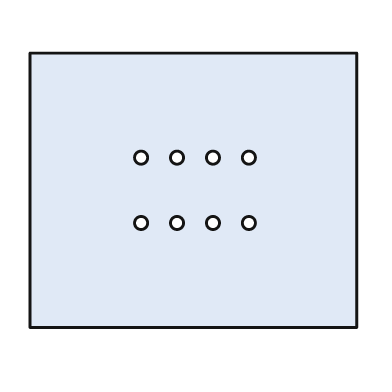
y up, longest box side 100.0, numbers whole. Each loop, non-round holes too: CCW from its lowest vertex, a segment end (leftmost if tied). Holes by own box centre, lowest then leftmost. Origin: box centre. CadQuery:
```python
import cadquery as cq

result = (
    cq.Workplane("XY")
    .moveTo(-50.0, -42.0)
    .lineTo(50.0, -42.0)
    .lineTo(50.0, 42.0)
    .lineTo(-50.0, 42.0)
    .close()
    .moveTo(-16.0, -10.0)
    .circle(2.0)
    .moveTo(-5.0, -10.0)
    .circle(2.0)
    .moveTo(6.0, -10.0)
    .circle(2.0)
    .moveTo(17.0, -10.0)
    .circle(2.0)
    .moveTo(-16.0, 10.0)
    .circle(2.0)
    .moveTo(-5.0, 10.0)
    .circle(2.0)
    .moveTo(6.0, 10.0)
    .circle(2.0)
    .moveTo(17.0, 10.0)
    .circle(2.0)
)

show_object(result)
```